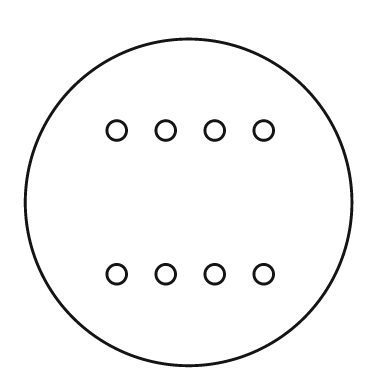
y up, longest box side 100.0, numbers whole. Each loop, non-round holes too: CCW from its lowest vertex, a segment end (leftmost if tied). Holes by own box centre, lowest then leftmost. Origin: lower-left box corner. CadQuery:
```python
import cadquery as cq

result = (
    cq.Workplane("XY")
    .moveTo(50.0, 50.0)
    .circle(50.0)
    .moveTo(28.0, 28.0)
    .circle(3.0)
    .moveTo(43.0, 28.0)
    .circle(3.0)
    .moveTo(58.0, 28.0)
    .circle(3.0)
    .moveTo(73.0, 28.0)
    .circle(3.0)
    .moveTo(28.0, 72.0)
    .circle(3.0)
    .moveTo(43.0, 72.0)
    .circle(3.0)
    .moveTo(58.0, 72.0)
    .circle(3.0)
    .moveTo(73.0, 72.0)
    .circle(3.0)
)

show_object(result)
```